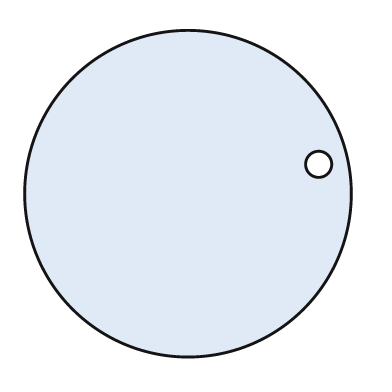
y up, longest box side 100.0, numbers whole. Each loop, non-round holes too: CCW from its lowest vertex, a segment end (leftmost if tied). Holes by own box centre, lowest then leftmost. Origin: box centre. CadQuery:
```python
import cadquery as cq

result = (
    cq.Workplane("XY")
    .moveTo(0.0, 0.0)
    .circle(50.0)
    .moveTo(40.0, 9.0)
    .circle(4.0)
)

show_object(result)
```